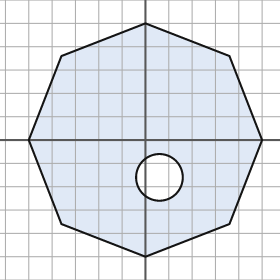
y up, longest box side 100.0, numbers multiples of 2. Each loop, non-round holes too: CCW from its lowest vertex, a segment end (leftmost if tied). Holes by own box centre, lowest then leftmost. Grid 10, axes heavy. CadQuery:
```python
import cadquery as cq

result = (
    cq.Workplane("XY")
    .moveTo(0.0, -50.0)
    .lineTo(36.0, -36.0)
    .lineTo(50.0, 0.0)
    .lineTo(36.0, 36.0)
    .lineTo(0.0, 50.0)
    .lineTo(-36.0, 36.0)
    .lineTo(-50.0, 0.0)
    .lineTo(-36.0, -36.0)
    .close()
    .moveTo(6.0, -16.0)
    .circle(10.0)
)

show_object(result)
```